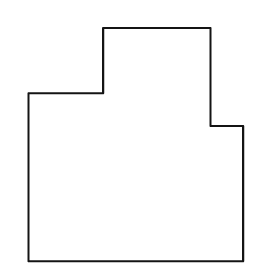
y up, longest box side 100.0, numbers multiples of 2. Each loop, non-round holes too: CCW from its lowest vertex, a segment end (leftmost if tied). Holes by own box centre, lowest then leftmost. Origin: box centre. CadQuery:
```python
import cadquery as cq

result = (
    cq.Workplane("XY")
    .moveTo(-46.0, -50.0)
    .lineTo(46.0, -50.0)
    .lineTo(46.0, 8.0)
    .lineTo(32.0, 8.0)
    .lineTo(32.0, 50.0)
    .lineTo(-14.0, 50.0)
    .lineTo(-14.0, 22.0)
    .lineTo(-46.0, 22.0)
    .close()
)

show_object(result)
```